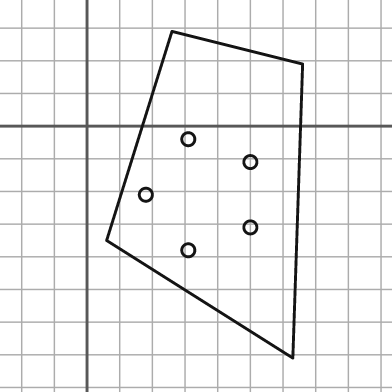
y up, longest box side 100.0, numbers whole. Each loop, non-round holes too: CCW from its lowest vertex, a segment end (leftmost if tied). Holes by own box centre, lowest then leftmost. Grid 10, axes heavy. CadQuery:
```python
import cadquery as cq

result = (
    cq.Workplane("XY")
    .moveTo(63.0, -71.0)
    .lineTo(66.0, 19.0)
    .lineTo(26.0, 29.0)
    .lineTo(6.0, -35.0)
    .close()
    .moveTo(31.0, -38.0)
    .circle(2.0)
    .moveTo(50.0, -31.0)
    .circle(2.0)
    .moveTo(18.0, -21.0)
    .circle(2.0)
    .moveTo(50.0, -11.0)
    .circle(2.0)
    .moveTo(31.0, -4.0)
    .circle(2.0)
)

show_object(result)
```